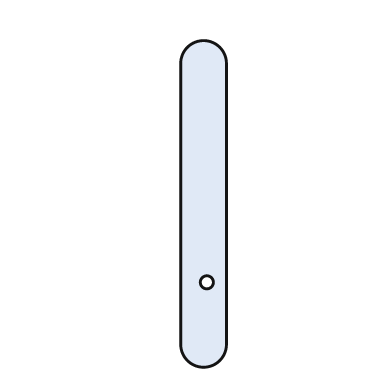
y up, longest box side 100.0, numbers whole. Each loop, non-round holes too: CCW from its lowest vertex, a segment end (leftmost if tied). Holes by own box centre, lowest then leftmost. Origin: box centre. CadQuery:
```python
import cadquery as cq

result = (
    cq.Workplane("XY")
    .moveTo(-7.0, -43.0)
    .threePointArc((0.0, -50.0), (7.0, -43.0))
    .lineTo(7.0, 43.0)
    .threePointArc((0.0, 50.0), (-7.0, 43.0))
    .close()
    .moveTo(1.0, -24.0)
    .circle(2.0)
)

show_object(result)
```